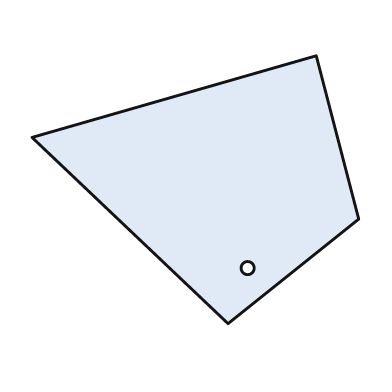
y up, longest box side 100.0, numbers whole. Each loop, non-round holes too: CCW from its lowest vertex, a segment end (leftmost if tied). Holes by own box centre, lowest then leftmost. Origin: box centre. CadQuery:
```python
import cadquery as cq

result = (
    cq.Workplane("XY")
    .moveTo(10.0, -41.0)
    .lineTo(50.0, -9.0)
    .lineTo(37.0, 41.0)
    .lineTo(-50.0, 16.0)
    .close()
    .moveTo(16.0, -24.0)
    .circle(2.0)
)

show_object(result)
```